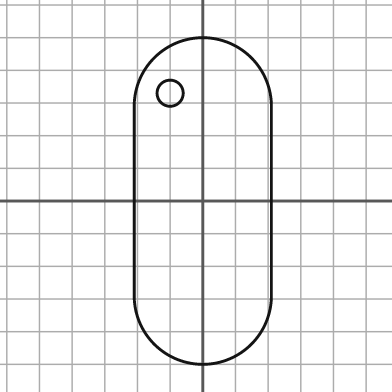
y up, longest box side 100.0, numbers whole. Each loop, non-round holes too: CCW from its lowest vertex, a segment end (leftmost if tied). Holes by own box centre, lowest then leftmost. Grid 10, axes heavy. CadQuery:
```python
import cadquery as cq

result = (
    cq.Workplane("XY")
    .moveTo(-21.0, -29.0)
    .threePointArc((0.0, -50.0), (21.0, -29.0))
    .lineTo(21.0, 29.0)
    .threePointArc((0.0, 50.0), (-21.0, 29.0))
    .close()
    .moveTo(-10.0, 33.0)
    .circle(4.0)
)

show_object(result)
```